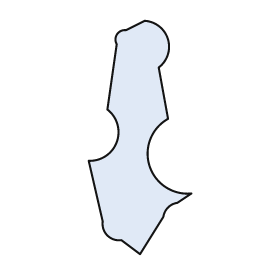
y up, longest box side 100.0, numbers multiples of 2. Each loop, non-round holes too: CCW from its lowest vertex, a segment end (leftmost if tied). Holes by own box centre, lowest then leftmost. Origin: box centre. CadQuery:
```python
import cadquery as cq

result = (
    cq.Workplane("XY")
    .moveTo(0.0, -50.0)
    .lineTo(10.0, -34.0)
    .threePointArc((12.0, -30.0), (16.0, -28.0))
    .lineTo(22.0, -24.0)
    .threePointArc((4.0, -12.0), (12.0, 8.0))
    .lineTo(8.0, 30.0)
    .threePointArc((12.0, 42.0), (2.0, 50.0))
    .lineTo(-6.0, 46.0)
    .threePointArc((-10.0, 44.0), (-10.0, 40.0))
    .lineTo(-14.0, 12.0)
    .threePointArc((-10.0, -2.0), (-22.0, -10.0))
    .lineTo(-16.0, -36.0)
    .threePointArc((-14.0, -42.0), (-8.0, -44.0))
    .close()
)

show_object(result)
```